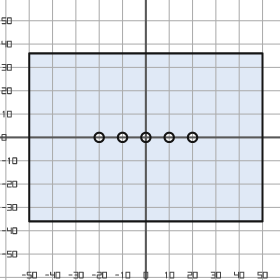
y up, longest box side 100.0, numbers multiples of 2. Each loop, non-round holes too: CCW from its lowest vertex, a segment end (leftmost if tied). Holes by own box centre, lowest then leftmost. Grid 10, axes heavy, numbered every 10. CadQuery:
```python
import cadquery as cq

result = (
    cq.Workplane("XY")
    .moveTo(-50.0, -36.0)
    .lineTo(50.0, -36.0)
    .lineTo(50.0, 36.0)
    .lineTo(-50.0, 36.0)
    .close()
    .moveTo(-20.0, 0.0)
    .circle(2.0)
    .moveTo(-10.0, 0.0)
    .circle(2.0)
    .moveTo(0.0, 0.0)
    .circle(2.0)
    .moveTo(10.0, 0.0)
    .circle(2.0)
    .moveTo(20.0, 0.0)
    .circle(2.0)
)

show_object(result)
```